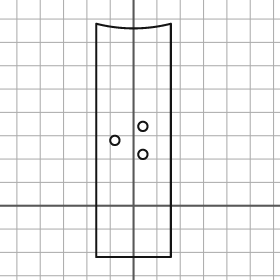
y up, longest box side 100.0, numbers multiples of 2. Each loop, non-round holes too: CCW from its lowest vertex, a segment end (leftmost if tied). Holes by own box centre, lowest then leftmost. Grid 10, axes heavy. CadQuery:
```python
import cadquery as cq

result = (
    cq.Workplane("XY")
    .moveTo(-16.0, -22.0)
    .lineTo(16.0, -22.0)
    .lineTo(16.0, 78.0)
    .threePointArc((0.0, 76.0), (-16.0, 78.0))
    .close()
    .moveTo(4.0, 22.0)
    .circle(2.0)
    .moveTo(-8.0, 28.0)
    .circle(2.0)
    .moveTo(4.0, 34.0)
    .circle(2.0)
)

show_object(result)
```